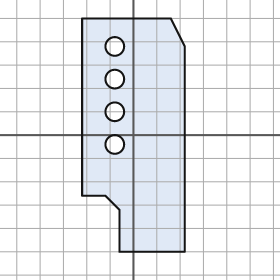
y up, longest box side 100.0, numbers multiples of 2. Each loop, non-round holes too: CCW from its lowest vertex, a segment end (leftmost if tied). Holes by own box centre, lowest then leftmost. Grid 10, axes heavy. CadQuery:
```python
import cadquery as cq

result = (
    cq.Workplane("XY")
    .moveTo(-6.0, -50.0)
    .lineTo(22.0, -50.0)
    .lineTo(22.0, 38.0)
    .lineTo(16.0, 50.0)
    .lineTo(-22.0, 50.0)
    .lineTo(-22.0, -26.0)
    .lineTo(-12.0, -26.0)
    .lineTo(-6.0, -32.0)
    .close()
    .moveTo(-8.0, -4.0)
    .circle(4.0)
    .moveTo(-8.0, 10.0)
    .circle(4.0)
    .moveTo(-8.0, 24.0)
    .circle(4.0)
    .moveTo(-8.0, 38.0)
    .circle(4.0)
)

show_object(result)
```